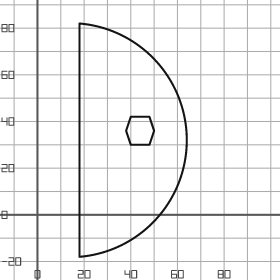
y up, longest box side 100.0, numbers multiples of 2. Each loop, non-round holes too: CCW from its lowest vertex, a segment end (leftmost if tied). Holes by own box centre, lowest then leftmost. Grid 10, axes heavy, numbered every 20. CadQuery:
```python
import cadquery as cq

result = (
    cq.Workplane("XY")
    .moveTo(18.0, -18.0)
    .threePointArc((64.0, 32.0), (18.0, 82.0))
    .close()
    .moveTo(40.0, 30.0)
    .lineTo(48.0, 30.0)
    .lineTo(50.0, 36.0)
    .lineTo(48.0, 42.0)
    .lineTo(40.0, 42.0)
    .lineTo(38.0, 36.0)
    .close()
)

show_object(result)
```